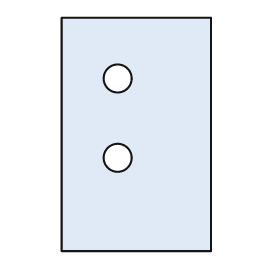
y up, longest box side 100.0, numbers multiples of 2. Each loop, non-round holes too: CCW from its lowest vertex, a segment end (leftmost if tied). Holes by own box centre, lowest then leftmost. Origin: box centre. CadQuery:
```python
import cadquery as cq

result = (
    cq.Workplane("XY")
    .moveTo(-32.0, -50.0)
    .lineTo(32.0, -50.0)
    .lineTo(32.0, 50.0)
    .lineTo(-32.0, 50.0)
    .close()
    .moveTo(-8.0, -10.0)
    .circle(6.0)
    .moveTo(-8.0, 24.0)
    .circle(6.0)
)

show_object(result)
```